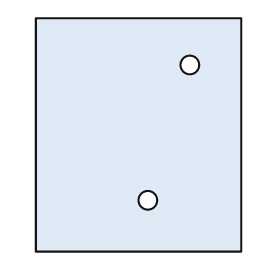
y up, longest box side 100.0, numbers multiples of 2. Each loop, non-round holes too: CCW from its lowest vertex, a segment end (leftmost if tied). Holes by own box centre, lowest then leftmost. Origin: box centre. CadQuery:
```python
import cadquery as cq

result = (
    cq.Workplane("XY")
    .moveTo(-44.0, -50.0)
    .lineTo(44.0, -50.0)
    .lineTo(44.0, 50.0)
    .lineTo(-44.0, 50.0)
    .close()
    .moveTo(4.0, -28.0)
    .circle(4.0)
    .moveTo(22.0, 30.0)
    .circle(4.0)
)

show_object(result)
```